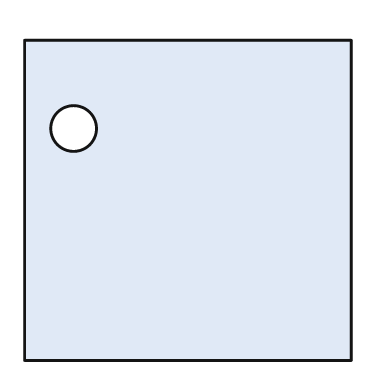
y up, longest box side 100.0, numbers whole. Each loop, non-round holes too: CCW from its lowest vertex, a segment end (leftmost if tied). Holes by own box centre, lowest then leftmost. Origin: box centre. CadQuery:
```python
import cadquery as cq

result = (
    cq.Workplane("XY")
    .moveTo(-50.0, -49.0)
    .lineTo(50.0, -49.0)
    .lineTo(50.0, 49.0)
    .lineTo(-50.0, 49.0)
    .close()
    .moveTo(-35.0, 22.0)
    .circle(7.0)
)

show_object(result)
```